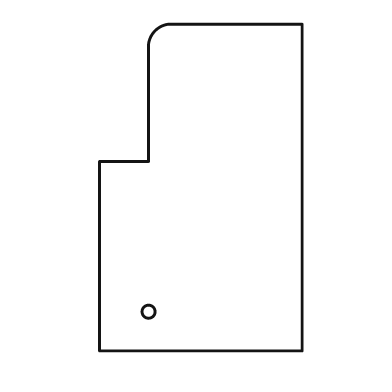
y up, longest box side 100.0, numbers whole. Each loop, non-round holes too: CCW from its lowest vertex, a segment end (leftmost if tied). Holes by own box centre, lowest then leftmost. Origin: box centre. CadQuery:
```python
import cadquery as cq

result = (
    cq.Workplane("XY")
    .moveTo(-31.0, -50.0)
    .lineTo(31.0, -50.0)
    .lineTo(31.0, 50.0)
    .lineTo(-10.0, 50.0)
    .threePointArc((-14.0, 48.0), (-16.0, 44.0))
    .lineTo(-16.0, 8.0)
    .lineTo(-31.0, 8.0)
    .close()
    .moveTo(-16.0, -38.0)
    .circle(2.0)
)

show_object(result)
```